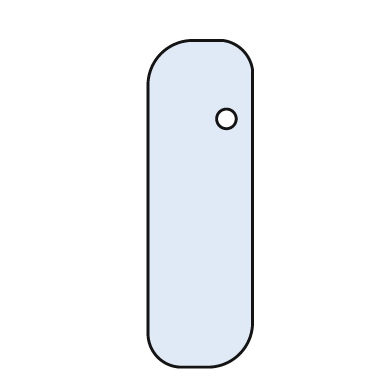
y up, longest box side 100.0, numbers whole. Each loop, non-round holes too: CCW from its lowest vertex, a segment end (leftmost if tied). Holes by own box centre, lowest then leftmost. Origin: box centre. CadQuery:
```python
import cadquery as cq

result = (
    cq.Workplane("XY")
    .moveTo(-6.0, -50.0)
    .lineTo(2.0, -50.0)
    .threePointArc((12.0, -46.0), (16.0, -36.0))
    .lineTo(16.0, 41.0)
    .threePointArc((13.0, 47.0), (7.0, 50.0))
    .lineTo(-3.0, 50.0)
    .threePointArc((-12.0, 46.0), (-16.0, 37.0))
    .lineTo(-16.0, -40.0)
    .threePointArc((-13.0, -47.0), (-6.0, -50.0))
    .close()
    .moveTo(8.0, 26.0)
    .circle(3.0)
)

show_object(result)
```